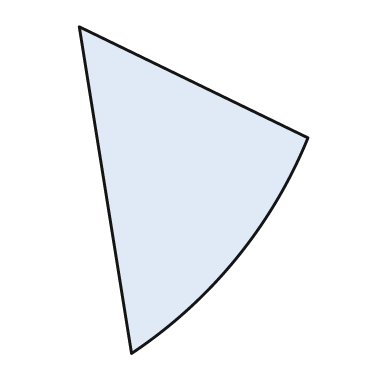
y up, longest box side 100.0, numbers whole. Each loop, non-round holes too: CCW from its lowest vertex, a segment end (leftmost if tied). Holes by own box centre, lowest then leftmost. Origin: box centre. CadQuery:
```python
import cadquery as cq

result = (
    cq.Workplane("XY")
    .moveTo(-19.0, -50.0)
    .threePointArc((13.0, -21.0), (35.0, 16.0))
    .lineTo(-35.0, 50.0)
    .close()
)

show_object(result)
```